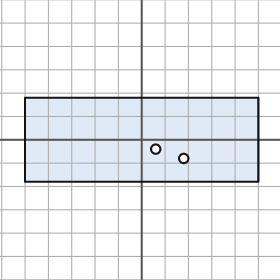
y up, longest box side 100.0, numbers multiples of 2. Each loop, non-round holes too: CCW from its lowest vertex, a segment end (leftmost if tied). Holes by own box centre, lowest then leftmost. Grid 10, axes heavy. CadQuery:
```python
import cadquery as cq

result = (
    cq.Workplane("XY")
    .moveTo(-50.0, -18.0)
    .lineTo(50.0, -18.0)
    .lineTo(50.0, 18.0)
    .lineTo(-50.0, 18.0)
    .close()
    .moveTo(18.0, -8.0)
    .circle(2.0)
    .moveTo(6.0, -4.0)
    .circle(2.0)
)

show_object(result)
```